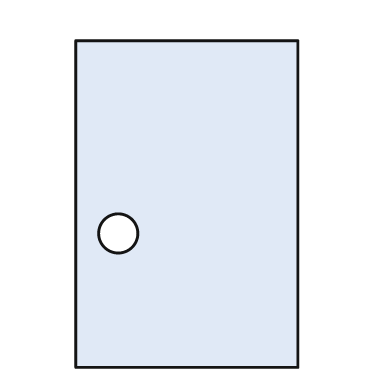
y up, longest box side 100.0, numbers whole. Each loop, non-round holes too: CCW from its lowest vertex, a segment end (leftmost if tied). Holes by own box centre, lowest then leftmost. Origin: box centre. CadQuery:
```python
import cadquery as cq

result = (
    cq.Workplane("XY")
    .moveTo(-34.0, -50.0)
    .lineTo(34.0, -50.0)
    .lineTo(34.0, 50.0)
    .lineTo(-34.0, 50.0)
    .close()
    .moveTo(-21.0, -9.0)
    .circle(6.0)
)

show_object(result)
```